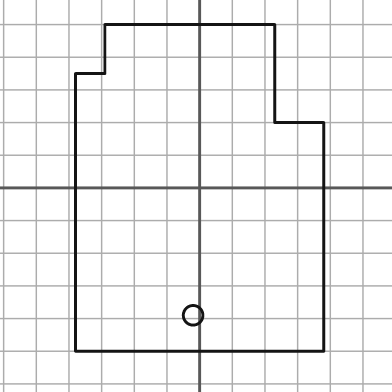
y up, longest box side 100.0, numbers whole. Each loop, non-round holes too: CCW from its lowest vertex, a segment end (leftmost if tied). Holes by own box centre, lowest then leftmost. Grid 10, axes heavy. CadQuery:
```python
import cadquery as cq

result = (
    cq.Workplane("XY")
    .moveTo(-38.0, -50.0)
    .lineTo(38.0, -50.0)
    .lineTo(38.0, 20.0)
    .lineTo(23.0, 20.0)
    .lineTo(23.0, 50.0)
    .lineTo(-29.0, 50.0)
    .lineTo(-29.0, 35.0)
    .lineTo(-38.0, 35.0)
    .close()
    .moveTo(-2.0, -39.0)
    .circle(3.0)
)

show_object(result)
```